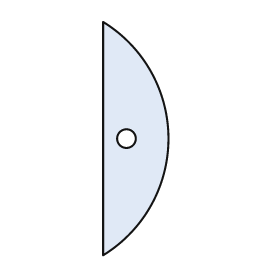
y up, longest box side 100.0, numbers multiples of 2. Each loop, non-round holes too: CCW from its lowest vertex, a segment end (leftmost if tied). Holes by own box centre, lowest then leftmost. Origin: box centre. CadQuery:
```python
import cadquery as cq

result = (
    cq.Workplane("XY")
    .moveTo(-14.0, -50.0)
    .threePointArc((14.0, 0.0), (-14.0, 50.0))
    .close()
    .moveTo(-4.0, 0.0)
    .circle(4.0)
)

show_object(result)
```